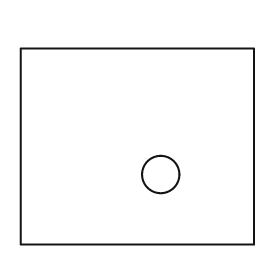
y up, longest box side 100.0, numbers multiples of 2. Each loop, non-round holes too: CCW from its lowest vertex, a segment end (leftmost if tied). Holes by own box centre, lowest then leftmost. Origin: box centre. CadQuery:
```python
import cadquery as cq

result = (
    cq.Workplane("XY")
    .moveTo(-50.0, -42.0)
    .lineTo(50.0, -42.0)
    .lineTo(50.0, 42.0)
    .lineTo(-50.0, 42.0)
    .close()
    .moveTo(10.0, -12.0)
    .circle(8.0)
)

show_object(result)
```